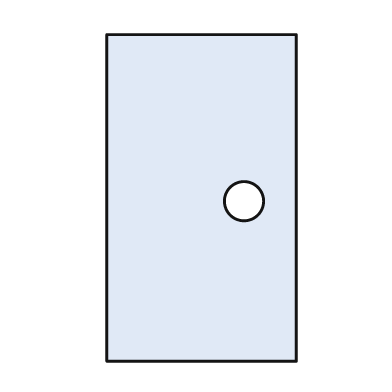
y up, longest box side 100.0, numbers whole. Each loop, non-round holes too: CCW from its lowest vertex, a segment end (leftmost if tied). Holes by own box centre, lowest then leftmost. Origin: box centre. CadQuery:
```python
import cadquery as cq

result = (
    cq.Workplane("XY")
    .moveTo(-29.0, -50.0)
    .lineTo(29.0, -50.0)
    .lineTo(29.0, 50.0)
    .lineTo(-29.0, 50.0)
    .close()
    .moveTo(13.0, -1.0)
    .circle(6.0)
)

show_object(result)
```